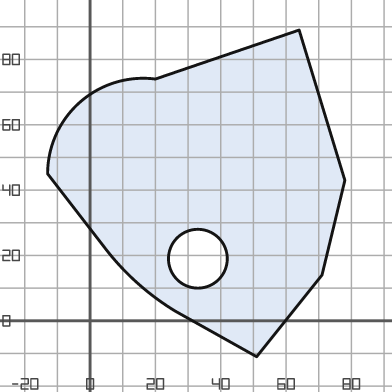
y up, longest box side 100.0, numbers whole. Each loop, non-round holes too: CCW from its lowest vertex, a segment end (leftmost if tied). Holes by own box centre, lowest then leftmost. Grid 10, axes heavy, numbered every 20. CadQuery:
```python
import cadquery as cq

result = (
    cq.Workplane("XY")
    .moveTo(51.0, -11.0)
    .lineTo(71.0, 14.0)
    .lineTo(78.0, 43.0)
    .lineTo(64.0, 89.0)
    .lineTo(20.0, 74.0)
    .threePointArc((-3.0, 67.0), (-13.0, 45.0))
    .lineTo(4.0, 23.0)
    .threePointArc((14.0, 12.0), (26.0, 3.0))
    .close()
    .moveTo(33.0, 19.0)
    .circle(9.0)
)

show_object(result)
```